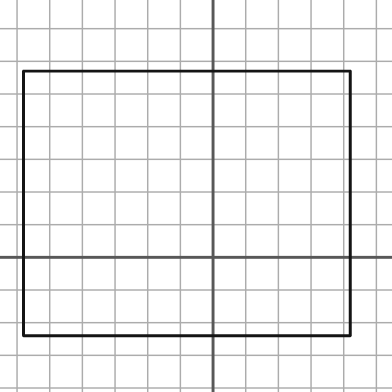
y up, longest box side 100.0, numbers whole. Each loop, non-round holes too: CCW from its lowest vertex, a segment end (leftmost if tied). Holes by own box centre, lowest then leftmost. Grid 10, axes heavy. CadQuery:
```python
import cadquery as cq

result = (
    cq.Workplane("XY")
    .moveTo(-58.0, -24.0)
    .lineTo(42.0, -24.0)
    .lineTo(42.0, 57.0)
    .lineTo(-58.0, 57.0)
    .close()
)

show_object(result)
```